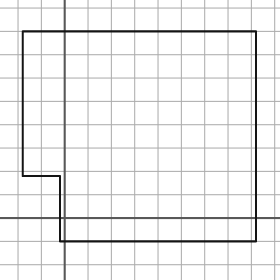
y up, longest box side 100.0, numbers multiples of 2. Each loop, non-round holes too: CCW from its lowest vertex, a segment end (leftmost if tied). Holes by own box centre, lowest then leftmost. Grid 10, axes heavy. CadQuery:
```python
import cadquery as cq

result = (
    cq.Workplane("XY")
    .moveTo(-2.0, -10.0)
    .lineTo(82.0, -10.0)
    .lineTo(82.0, 80.0)
    .lineTo(-18.0, 80.0)
    .lineTo(-18.0, 18.0)
    .lineTo(-2.0, 18.0)
    .close()
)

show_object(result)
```